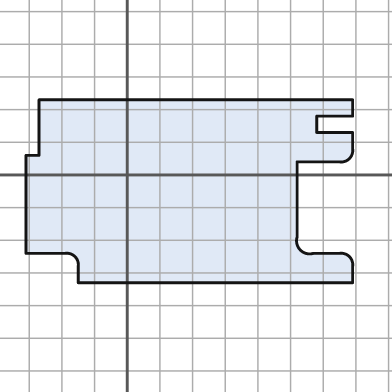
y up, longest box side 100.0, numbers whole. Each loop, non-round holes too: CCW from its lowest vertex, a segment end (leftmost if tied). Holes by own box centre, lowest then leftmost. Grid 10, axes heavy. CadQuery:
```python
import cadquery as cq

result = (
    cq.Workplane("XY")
    .moveTo(-15.0, -33.0)
    .lineTo(69.0, -33.0)
    .lineTo(69.0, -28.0)
    .threePointArc((68.0, -25.0), (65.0, -24.0))
    .lineTo(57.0, -24.0)
    .threePointArc((53.0, -23.0), (52.0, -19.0))
    .lineTo(52.0, 4.0)
    .lineTo(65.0, 4.0)
    .threePointArc((68.0, 5.0), (69.0, 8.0))
    .lineTo(69.0, 13.0)
    .lineTo(58.0, 13.0)
    .lineTo(58.0, 18.0)
    .lineTo(69.0, 18.0)
    .lineTo(69.0, 23.0)
    .lineTo(-27.0, 23.0)
    .lineTo(-27.0, 6.0)
    .lineTo(-31.0, 6.0)
    .lineTo(-31.0, -24.0)
    .lineTo(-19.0, -24.0)
    .threePointArc((-16.0, -25.0), (-15.0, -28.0))
    .close()
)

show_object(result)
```